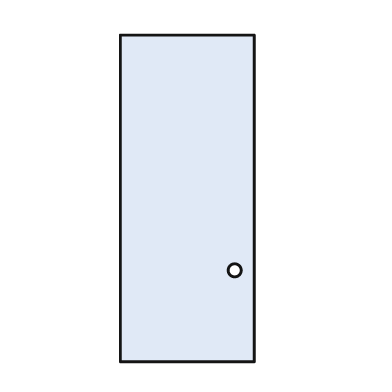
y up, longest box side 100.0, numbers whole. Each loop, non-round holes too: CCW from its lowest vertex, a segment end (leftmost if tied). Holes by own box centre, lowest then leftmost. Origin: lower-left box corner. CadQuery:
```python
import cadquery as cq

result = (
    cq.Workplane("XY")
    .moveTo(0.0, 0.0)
    .lineTo(41.0, 0.0)
    .lineTo(41.0, 100.0)
    .lineTo(0.0, 100.0)
    .close()
    .moveTo(35.0, 28.0)
    .circle(2.0)
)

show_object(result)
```